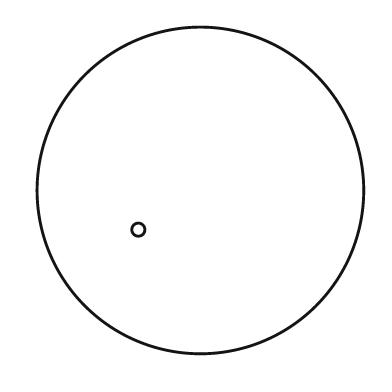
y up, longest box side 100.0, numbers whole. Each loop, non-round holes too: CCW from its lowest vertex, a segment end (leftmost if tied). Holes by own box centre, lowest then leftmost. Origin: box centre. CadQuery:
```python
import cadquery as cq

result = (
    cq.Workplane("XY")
    .moveTo(0.0, 0.0)
    .circle(50.0)
    .moveTo(-19.0, -12.0)
    .circle(2.0)
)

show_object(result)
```